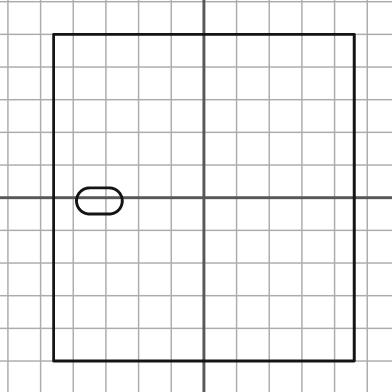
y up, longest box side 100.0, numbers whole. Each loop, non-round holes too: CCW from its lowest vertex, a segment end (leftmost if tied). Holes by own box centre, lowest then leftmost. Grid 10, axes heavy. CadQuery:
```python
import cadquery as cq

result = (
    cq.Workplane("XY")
    .moveTo(-46.0, -50.0)
    .lineTo(46.0, -50.0)
    .lineTo(46.0, 50.0)
    .lineTo(-46.0, 50.0)
    .close()
    .moveTo(-35.0, -5.0)
    .lineTo(-29.0, -5.0)
    .threePointArc((-25.0, -1.0), (-29.0, 3.0))
    .lineTo(-35.0, 3.0)
    .threePointArc((-39.0, -1.0), (-35.0, -5.0))
    .close()
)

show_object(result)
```